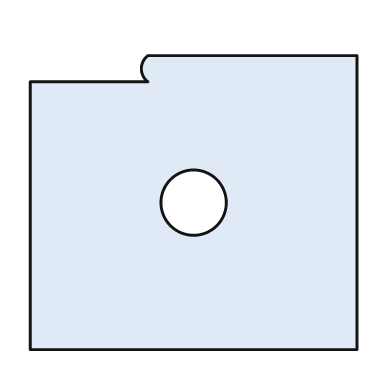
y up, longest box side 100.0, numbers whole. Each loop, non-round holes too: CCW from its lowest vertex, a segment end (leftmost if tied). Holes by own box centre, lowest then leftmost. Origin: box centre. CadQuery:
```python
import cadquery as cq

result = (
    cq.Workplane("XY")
    .moveTo(-50.0, -45.0)
    .lineTo(50.0, -45.0)
    .lineTo(50.0, 45.0)
    .lineTo(-14.0, 45.0)
    .threePointArc((-16.0, 41.0), (-14.0, 37.0))
    .lineTo(-50.0, 37.0)
    .close()
    .moveTo(0.0, 0.0)
    .circle(10.0)
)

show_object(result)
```